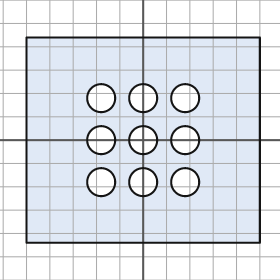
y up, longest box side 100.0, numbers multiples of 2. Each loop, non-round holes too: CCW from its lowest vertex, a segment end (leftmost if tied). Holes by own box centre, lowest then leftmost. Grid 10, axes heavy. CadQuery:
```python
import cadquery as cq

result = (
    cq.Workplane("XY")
    .moveTo(-50.0, -44.0)
    .lineTo(50.0, -44.0)
    .lineTo(50.0, 44.0)
    .lineTo(-50.0, 44.0)
    .close()
    .moveTo(-18.0, -18.0)
    .circle(6.0)
    .moveTo(0.0, -18.0)
    .circle(6.0)
    .moveTo(18.0, -18.0)
    .circle(6.0)
    .moveTo(-18.0, 0.0)
    .circle(6.0)
    .moveTo(0.0, 0.0)
    .circle(6.0)
    .moveTo(18.0, 0.0)
    .circle(6.0)
    .moveTo(-18.0, 18.0)
    .circle(6.0)
    .moveTo(0.0, 18.0)
    .circle(6.0)
    .moveTo(18.0, 18.0)
    .circle(6.0)
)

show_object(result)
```